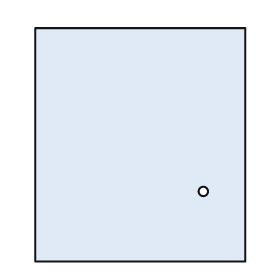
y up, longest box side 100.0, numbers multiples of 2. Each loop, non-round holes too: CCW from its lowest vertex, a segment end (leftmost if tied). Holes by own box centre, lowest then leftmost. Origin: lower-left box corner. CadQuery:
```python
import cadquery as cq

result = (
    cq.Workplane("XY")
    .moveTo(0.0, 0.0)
    .lineTo(90.0, 0.0)
    .lineTo(90.0, 100.0)
    .lineTo(0.0, 100.0)
    .close()
    .moveTo(72.0, 30.0)
    .circle(2.0)
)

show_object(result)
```